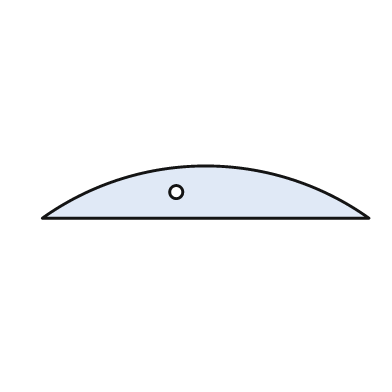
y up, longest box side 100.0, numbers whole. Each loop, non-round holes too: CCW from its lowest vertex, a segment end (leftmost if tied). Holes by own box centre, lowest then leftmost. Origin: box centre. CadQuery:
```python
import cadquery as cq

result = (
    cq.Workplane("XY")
    .moveTo(-50.0, -8.0)
    .lineTo(50.0, -8.0)
    .threePointArc((0.0, 8.0), (-50.0, -8.0))
    .close()
    .moveTo(-9.0, 0.0)
    .circle(2.0)
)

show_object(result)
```